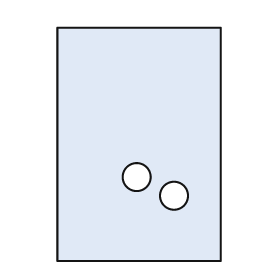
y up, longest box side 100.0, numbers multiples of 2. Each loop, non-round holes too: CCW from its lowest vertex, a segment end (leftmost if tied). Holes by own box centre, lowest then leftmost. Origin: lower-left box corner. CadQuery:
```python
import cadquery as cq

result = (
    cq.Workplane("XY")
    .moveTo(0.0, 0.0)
    .lineTo(70.0, 0.0)
    .lineTo(70.0, 100.0)
    .lineTo(0.0, 100.0)
    .close()
    .moveTo(50.0, 28.0)
    .circle(6.0)
    .moveTo(34.0, 36.0)
    .circle(6.0)
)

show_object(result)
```